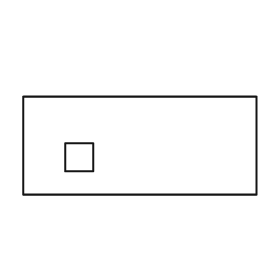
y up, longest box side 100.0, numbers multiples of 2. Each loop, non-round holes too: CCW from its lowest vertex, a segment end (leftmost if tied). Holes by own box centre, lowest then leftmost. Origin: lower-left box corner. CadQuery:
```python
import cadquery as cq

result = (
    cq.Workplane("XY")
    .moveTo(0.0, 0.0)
    .lineTo(100.0, 0.0)
    .lineTo(100.0, 42.0)
    .lineTo(0.0, 42.0)
    .close()
    .moveTo(18.0, 10.0)
    .lineTo(30.0, 10.0)
    .lineTo(30.0, 22.0)
    .lineTo(18.0, 22.0)
    .close()
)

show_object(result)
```